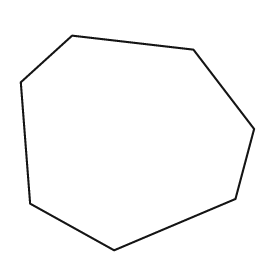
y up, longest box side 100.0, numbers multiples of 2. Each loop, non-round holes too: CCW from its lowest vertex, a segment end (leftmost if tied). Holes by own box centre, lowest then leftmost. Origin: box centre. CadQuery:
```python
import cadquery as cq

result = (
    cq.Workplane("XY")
    .moveTo(-10.0, -46.0)
    .lineTo(42.0, -24.0)
    .lineTo(50.0, 6.0)
    .lineTo(24.0, 40.0)
    .lineTo(-28.0, 46.0)
    .lineTo(-50.0, 26.0)
    .lineTo(-46.0, -26.0)
    .close()
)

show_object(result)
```